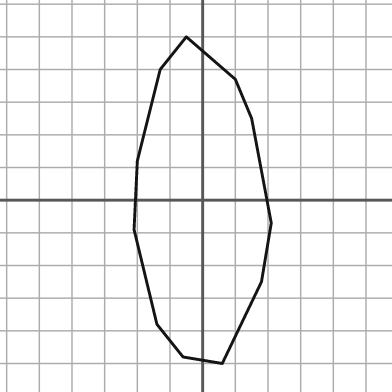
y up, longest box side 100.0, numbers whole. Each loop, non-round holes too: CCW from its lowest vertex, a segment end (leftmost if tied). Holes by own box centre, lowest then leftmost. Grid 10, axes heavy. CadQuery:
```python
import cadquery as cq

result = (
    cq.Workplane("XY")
    .moveTo(6.0, -50.0)
    .lineTo(18.0, -25.0)
    .lineTo(21.0, -7.0)
    .lineTo(15.0, 25.0)
    .lineTo(10.0, 37.0)
    .lineTo(-5.0, 50.0)
    .lineTo(-13.0, 40.0)
    .lineTo(-20.0, 12.0)
    .lineTo(-21.0, -9.0)
    .lineTo(-14.0, -38.0)
    .lineTo(-6.0, -48.0)
    .close()
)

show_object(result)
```